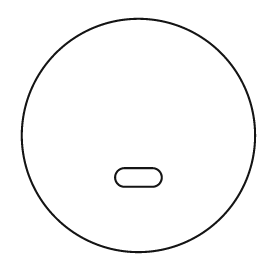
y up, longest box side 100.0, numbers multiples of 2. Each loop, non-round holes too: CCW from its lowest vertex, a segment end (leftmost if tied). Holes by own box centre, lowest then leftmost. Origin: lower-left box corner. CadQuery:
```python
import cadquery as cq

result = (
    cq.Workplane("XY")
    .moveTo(50.0, 50.0)
    .circle(50.0)
    .moveTo(44.0, 28.0)
    .lineTo(56.0, 28.0)
    .threePointArc((60.0, 32.0), (56.0, 36.0))
    .lineTo(44.0, 36.0)
    .threePointArc((40.0, 32.0), (44.0, 28.0))
    .close()
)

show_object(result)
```